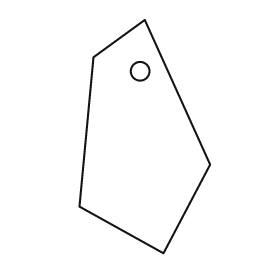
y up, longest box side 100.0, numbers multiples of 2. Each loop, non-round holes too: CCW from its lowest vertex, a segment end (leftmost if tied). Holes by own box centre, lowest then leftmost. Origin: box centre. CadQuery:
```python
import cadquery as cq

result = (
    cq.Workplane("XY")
    .moveTo(8.0, -50.0)
    .lineTo(28.0, -12.0)
    .lineTo(0.0, 50.0)
    .lineTo(-22.0, 34.0)
    .lineTo(-28.0, -30.0)
    .close()
    .moveTo(-2.0, 28.0)
    .circle(4.0)
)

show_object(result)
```